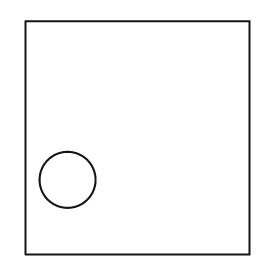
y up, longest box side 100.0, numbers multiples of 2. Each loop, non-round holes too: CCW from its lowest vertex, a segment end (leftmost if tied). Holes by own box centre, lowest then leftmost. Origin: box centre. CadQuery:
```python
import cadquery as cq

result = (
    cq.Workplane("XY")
    .moveTo(-48.0, -50.0)
    .lineTo(48.0, -50.0)
    .lineTo(48.0, 50.0)
    .lineTo(-48.0, 50.0)
    .close()
    .moveTo(-30.0, -18.0)
    .circle(12.0)
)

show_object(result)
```